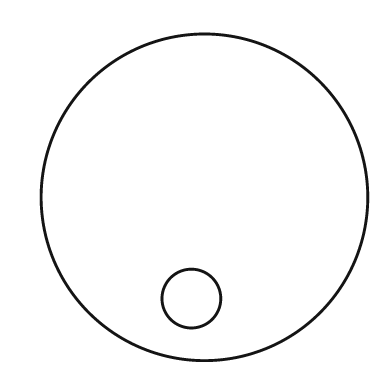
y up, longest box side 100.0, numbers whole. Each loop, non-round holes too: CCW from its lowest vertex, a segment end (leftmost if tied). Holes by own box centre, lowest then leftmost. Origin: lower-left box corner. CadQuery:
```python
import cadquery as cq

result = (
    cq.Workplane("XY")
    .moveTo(50.0, 50.0)
    .circle(50.0)
    .moveTo(46.0, 19.0)
    .circle(9.0)
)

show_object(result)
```